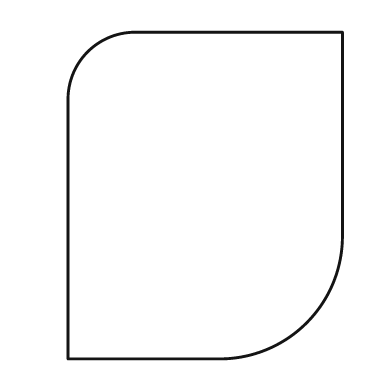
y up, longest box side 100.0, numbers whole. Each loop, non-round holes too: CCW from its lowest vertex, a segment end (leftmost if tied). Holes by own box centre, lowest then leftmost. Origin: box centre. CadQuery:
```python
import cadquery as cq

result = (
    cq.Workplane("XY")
    .moveTo(-42.0, -50.0)
    .lineTo(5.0, -50.0)
    .threePointArc((31.0, -39.0), (42.0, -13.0))
    .lineTo(42.0, 50.0)
    .lineTo(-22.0, 50.0)
    .threePointArc((-36.0, 44.0), (-42.0, 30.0))
    .close()
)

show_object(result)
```